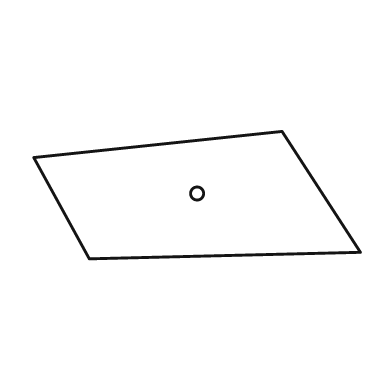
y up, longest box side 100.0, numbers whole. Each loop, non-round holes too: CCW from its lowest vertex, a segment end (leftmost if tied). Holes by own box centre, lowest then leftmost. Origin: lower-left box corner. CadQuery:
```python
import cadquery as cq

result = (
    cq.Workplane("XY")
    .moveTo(17.0, 0.0)
    .lineTo(100.0, 2.0)
    .lineTo(76.0, 39.0)
    .lineTo(0.0, 31.0)
    .close()
    .moveTo(50.0, 20.0)
    .circle(2.0)
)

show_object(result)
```